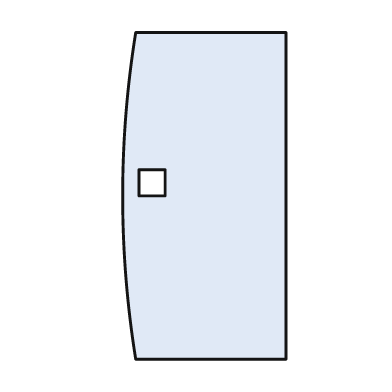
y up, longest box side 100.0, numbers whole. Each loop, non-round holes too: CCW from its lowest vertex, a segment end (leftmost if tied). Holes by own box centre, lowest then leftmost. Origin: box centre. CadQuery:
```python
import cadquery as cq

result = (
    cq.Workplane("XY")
    .moveTo(-21.0, -50.0)
    .lineTo(25.0, -50.0)
    .lineTo(25.0, 50.0)
    .lineTo(-21.0, 50.0)
    .threePointArc((-25.0, 0.0), (-21.0, -50.0))
    .close()
    .moveTo(-20.0, 0.0)
    .lineTo(-12.0, 0.0)
    .lineTo(-12.0, 8.0)
    .lineTo(-20.0, 8.0)
    .close()
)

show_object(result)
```